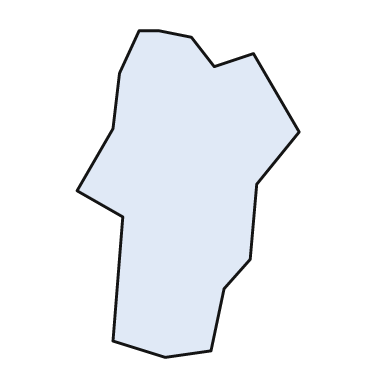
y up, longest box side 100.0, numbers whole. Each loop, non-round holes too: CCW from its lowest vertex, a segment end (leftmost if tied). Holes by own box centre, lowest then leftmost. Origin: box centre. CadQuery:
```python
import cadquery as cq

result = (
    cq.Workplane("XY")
    .moveTo(-7.0, -50.0)
    .lineTo(7.0, -48.0)
    .lineTo(11.0, -29.0)
    .lineTo(19.0, -20.0)
    .lineTo(21.0, 3.0)
    .lineTo(34.0, 19.0)
    .lineTo(20.0, 43.0)
    .lineTo(8.0, 39.0)
    .lineTo(1.0, 48.0)
    .lineTo(-9.0, 50.0)
    .lineTo(-15.0, 50.0)
    .lineTo(-21.0, 37.0)
    .lineTo(-23.0, 20.0)
    .lineTo(-34.0, 1.0)
    .lineTo(-20.0, -7.0)
    .lineTo(-23.0, -45.0)
    .close()
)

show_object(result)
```